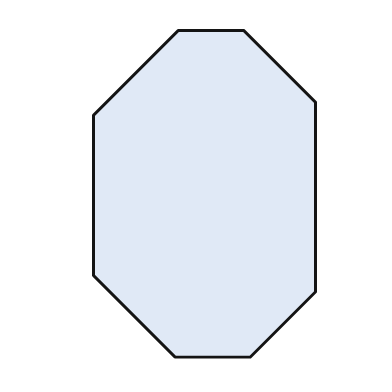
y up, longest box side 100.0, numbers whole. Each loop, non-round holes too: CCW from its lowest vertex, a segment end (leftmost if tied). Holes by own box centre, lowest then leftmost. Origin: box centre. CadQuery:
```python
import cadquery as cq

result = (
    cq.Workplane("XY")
    .moveTo(-9.0, -50.0)
    .lineTo(14.0, -50.0)
    .lineTo(34.0, -30.0)
    .lineTo(34.0, 28.0)
    .lineTo(12.0, 50.0)
    .lineTo(-8.0, 50.0)
    .lineTo(-34.0, 24.0)
    .lineTo(-34.0, -25.0)
    .close()
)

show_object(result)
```